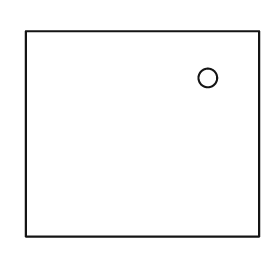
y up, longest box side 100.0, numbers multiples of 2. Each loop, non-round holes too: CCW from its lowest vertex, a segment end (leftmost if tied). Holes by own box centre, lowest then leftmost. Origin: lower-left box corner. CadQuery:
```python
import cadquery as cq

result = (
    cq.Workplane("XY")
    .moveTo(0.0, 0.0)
    .lineTo(100.0, 0.0)
    .lineTo(100.0, 88.0)
    .lineTo(0.0, 88.0)
    .close()
    .moveTo(78.0, 68.0)
    .circle(4.0)
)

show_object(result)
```